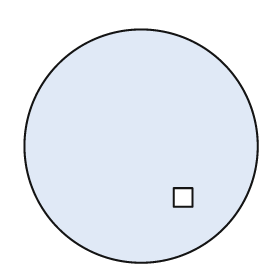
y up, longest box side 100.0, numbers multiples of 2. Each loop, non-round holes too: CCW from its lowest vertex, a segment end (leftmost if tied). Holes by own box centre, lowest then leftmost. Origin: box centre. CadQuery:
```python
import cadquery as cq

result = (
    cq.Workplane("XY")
    .moveTo(0.0, 0.0)
    .circle(50.0)
    .moveTo(14.0, -26.0)
    .lineTo(22.0, -26.0)
    .lineTo(22.0, -18.0)
    .lineTo(14.0, -18.0)
    .close()
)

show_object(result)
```